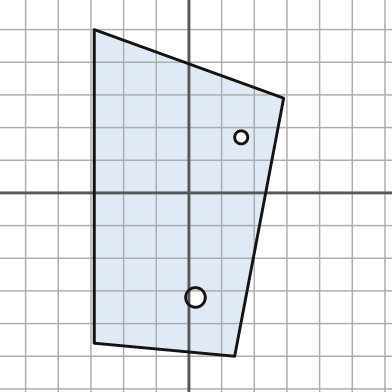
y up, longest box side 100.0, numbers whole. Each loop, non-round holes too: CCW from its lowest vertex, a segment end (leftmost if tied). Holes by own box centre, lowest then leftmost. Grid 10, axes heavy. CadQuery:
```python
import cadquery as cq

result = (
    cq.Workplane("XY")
    .moveTo(14.0, -50.0)
    .lineTo(29.0, 29.0)
    .lineTo(-29.0, 50.0)
    .lineTo(-29.0, -46.0)
    .close()
    .moveTo(2.0, -32.0)
    .circle(3.0)
    .moveTo(16.0, 17.0)
    .circle(2.0)
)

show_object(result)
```